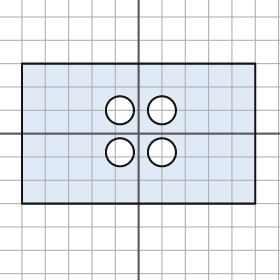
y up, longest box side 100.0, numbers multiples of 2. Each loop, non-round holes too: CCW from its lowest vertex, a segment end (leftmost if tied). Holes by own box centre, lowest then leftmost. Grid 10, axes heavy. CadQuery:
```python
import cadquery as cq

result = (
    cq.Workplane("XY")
    .moveTo(-50.0, -30.0)
    .lineTo(50.0, -30.0)
    .lineTo(50.0, 30.0)
    .lineTo(-50.0, 30.0)
    .close()
    .moveTo(-8.0, -8.0)
    .circle(6.0)
    .moveTo(10.0, -8.0)
    .circle(6.0)
    .moveTo(-8.0, 10.0)
    .circle(6.0)
    .moveTo(10.0, 10.0)
    .circle(6.0)
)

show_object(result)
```